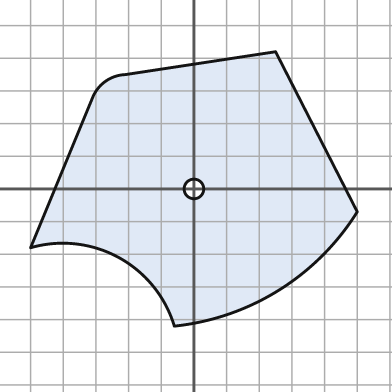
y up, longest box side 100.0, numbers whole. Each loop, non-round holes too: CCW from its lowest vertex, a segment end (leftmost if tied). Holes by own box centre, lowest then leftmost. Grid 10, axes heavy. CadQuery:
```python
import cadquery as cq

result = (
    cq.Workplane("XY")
    .moveTo(-6.0, -42.0)
    .threePointArc((26.0, -31.0), (50.0, -7.0))
    .lineTo(25.0, 42.0)
    .lineTo(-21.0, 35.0)
    .threePointArc((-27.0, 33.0), (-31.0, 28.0))
    .lineTo(-50.0, -18.0)
    .threePointArc((-23.0, -21.0), (-6.0, -42.0))
    .close()
    .moveTo(0.0, 0.0)
    .circle(3.0)
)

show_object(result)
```